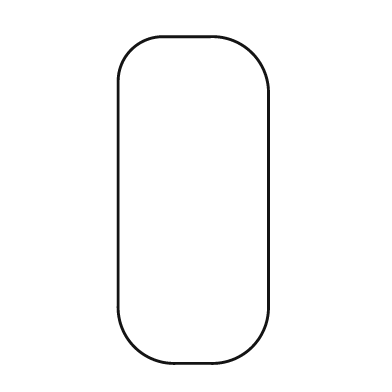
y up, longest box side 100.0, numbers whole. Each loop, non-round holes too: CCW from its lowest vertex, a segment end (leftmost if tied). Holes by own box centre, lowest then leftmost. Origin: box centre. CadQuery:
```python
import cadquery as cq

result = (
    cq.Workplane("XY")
    .moveTo(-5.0, -50.0)
    .lineTo(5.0, -50.0)
    .threePointArc((18.0, -45.0), (23.0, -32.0))
    .lineTo(23.0, 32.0)
    .threePointArc((18.0, 45.0), (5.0, 50.0))
    .lineTo(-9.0, 50.0)
    .threePointArc((-19.0, 46.0), (-23.0, 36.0))
    .lineTo(-23.0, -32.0)
    .threePointArc((-18.0, -45.0), (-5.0, -50.0))
    .close()
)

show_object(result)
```